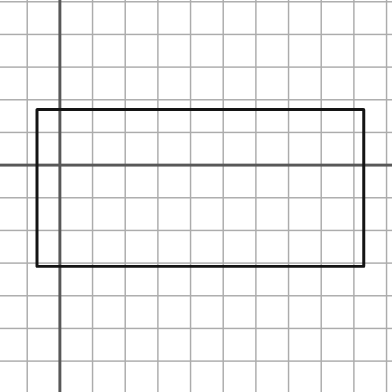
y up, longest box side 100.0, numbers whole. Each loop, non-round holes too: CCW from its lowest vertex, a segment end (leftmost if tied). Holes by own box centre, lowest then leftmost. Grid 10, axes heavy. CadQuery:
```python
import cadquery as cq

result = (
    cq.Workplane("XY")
    .moveTo(-7.0, -31.0)
    .lineTo(93.0, -31.0)
    .lineTo(93.0, 17.0)
    .lineTo(-7.0, 17.0)
    .close()
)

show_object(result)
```